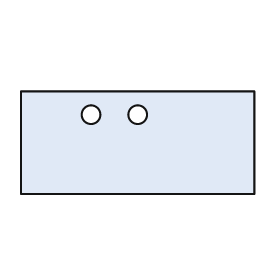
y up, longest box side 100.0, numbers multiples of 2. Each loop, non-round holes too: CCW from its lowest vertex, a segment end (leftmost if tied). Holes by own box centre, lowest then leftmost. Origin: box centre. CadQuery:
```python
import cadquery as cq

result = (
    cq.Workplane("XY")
    .moveTo(-50.0, -22.0)
    .lineTo(50.0, -22.0)
    .lineTo(50.0, 22.0)
    .lineTo(-50.0, 22.0)
    .close()
    .moveTo(-20.0, 12.0)
    .circle(4.0)
    .moveTo(0.0, 12.0)
    .circle(4.0)
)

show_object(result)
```